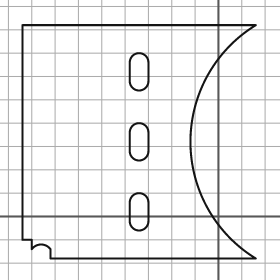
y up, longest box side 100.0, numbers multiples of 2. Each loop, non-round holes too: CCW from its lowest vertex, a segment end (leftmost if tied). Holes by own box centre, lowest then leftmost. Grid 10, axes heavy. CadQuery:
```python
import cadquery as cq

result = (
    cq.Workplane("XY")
    .moveTo(-72.0, -18.0)
    .lineTo(16.0, -18.0)
    .threePointArc((-12.0, 32.0), (16.0, 82.0))
    .lineTo(-84.0, 82.0)
    .lineTo(-84.0, -10.0)
    .lineTo(-80.0, -10.0)
    .lineTo(-80.0, -14.0)
    .threePointArc((-76.0, -12.0), (-72.0, -14.0))
    .close()
    .moveTo(-38.0, -2.0)
    .threePointArc((-34.0, -6.0), (-30.0, -2.0))
    .lineTo(-30.0, 6.0)
    .threePointArc((-34.0, 10.0), (-38.0, 6.0))
    .close()
    .moveTo(-38.0, 28.0)
    .threePointArc((-34.0, 24.0), (-30.0, 28.0))
    .lineTo(-30.0, 36.0)
    .threePointArc((-34.0, 40.0), (-38.0, 36.0))
    .close()
    .moveTo(-38.0, 58.0)
    .threePointArc((-34.0, 54.0), (-30.0, 58.0))
    .lineTo(-30.0, 66.0)
    .threePointArc((-34.0, 70.0), (-38.0, 66.0))
    .close()
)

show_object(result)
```